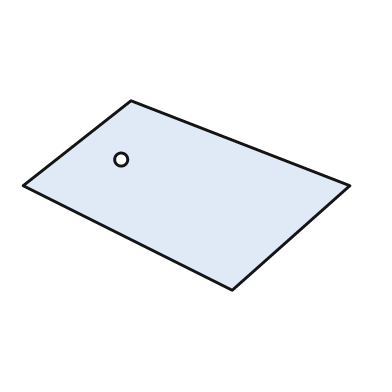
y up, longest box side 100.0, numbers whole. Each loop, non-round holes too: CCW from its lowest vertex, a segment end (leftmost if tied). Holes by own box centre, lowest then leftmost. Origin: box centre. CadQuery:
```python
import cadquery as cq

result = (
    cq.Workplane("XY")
    .moveTo(14.0, -29.0)
    .lineTo(50.0, 3.0)
    .lineTo(-17.0, 29.0)
    .lineTo(-50.0, 3.0)
    .close()
    .moveTo(-20.0, 11.0)
    .circle(2.0)
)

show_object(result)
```